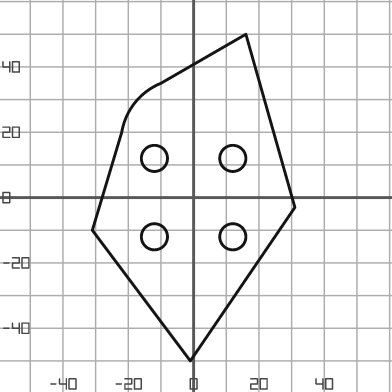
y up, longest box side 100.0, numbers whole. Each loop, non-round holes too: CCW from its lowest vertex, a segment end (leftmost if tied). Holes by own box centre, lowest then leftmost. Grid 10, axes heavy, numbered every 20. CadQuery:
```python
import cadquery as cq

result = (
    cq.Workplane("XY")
    .moveTo(-1.0, -50.0)
    .lineTo(31.0, -3.0)
    .lineTo(16.0, 50.0)
    .lineTo(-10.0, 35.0)
    .threePointArc((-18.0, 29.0), (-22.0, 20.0))
    .lineTo(-31.0, -10.0)
    .close()
    .moveTo(-12.0, -12.0)
    .circle(4.0)
    .moveTo(12.0, -12.0)
    .circle(4.0)
    .moveTo(-12.0, 12.0)
    .circle(4.0)
    .moveTo(12.0, 12.0)
    .circle(4.0)
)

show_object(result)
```